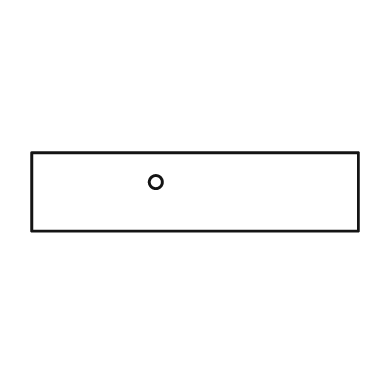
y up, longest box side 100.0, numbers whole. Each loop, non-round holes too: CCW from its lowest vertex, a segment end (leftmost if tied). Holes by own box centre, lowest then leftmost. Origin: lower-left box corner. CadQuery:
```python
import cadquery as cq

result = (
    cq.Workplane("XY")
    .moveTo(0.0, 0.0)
    .lineTo(100.0, 0.0)
    .lineTo(100.0, 24.0)
    .lineTo(0.0, 24.0)
    .close()
    .moveTo(38.0, 15.0)
    .circle(2.0)
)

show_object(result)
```